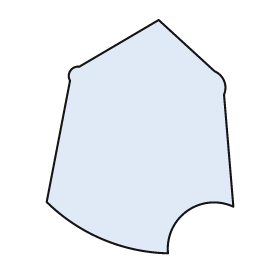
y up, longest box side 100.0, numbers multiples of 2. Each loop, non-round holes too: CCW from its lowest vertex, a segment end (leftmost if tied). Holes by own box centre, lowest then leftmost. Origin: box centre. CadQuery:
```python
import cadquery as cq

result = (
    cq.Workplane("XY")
    .moveTo(12.0, -50.0)
    .threePointArc((20.0, -32.0), (40.0, -30.0))
    .lineTo(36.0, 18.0)
    .threePointArc((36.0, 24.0), (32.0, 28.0))
    .lineTo(8.0, 50.0)
    .lineTo(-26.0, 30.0)
    .threePointArc((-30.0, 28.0), (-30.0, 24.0))
    .lineTo(-40.0, -28.0)
    .threePointArc((-16.0, -44.0), (12.0, -50.0))
    .close()
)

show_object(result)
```